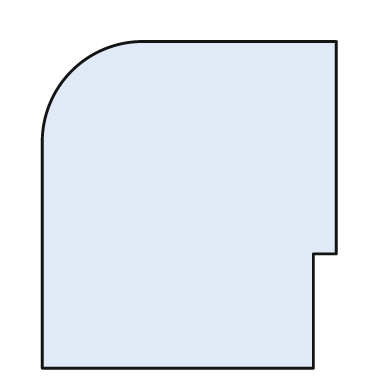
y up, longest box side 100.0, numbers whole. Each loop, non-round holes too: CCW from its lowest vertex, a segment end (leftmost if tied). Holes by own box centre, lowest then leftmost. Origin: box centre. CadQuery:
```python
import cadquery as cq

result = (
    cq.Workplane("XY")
    .moveTo(-45.0, -50.0)
    .lineTo(38.0, -50.0)
    .lineTo(38.0, -15.0)
    .lineTo(45.0, -15.0)
    .lineTo(45.0, 50.0)
    .lineTo(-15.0, 50.0)
    .threePointArc((-36.0, 41.0), (-45.0, 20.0))
    .close()
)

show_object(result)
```